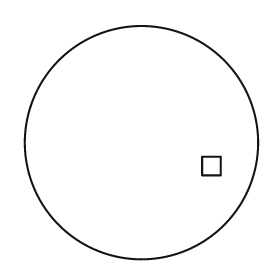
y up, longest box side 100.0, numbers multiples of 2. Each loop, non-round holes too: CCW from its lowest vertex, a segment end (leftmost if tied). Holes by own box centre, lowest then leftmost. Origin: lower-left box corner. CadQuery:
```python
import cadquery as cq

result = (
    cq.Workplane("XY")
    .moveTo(50.0, 50.0)
    .circle(50.0)
    .moveTo(76.0, 36.0)
    .lineTo(84.0, 36.0)
    .lineTo(84.0, 44.0)
    .lineTo(76.0, 44.0)
    .close()
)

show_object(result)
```